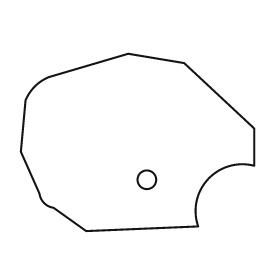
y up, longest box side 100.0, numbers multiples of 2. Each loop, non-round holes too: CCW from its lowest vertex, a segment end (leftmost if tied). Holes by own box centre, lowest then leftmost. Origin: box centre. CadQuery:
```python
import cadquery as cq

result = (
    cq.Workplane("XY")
    .moveTo(-22.0, -38.0)
    .lineTo(26.0, -36.0)
    .threePointArc((30.0, -16.0), (50.0, -10.0))
    .lineTo(50.0, 6.0)
    .lineTo(20.0, 34.0)
    .lineTo(-4.0, 38.0)
    .lineTo(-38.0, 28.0)
    .threePointArc((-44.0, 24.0), (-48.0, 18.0))
    .lineTo(-50.0, -4.0)
    .lineTo(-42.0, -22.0)
    .threePointArc((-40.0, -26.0), (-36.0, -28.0))
    .close()
    .moveTo(4.0, -16.0)
    .circle(4.0)
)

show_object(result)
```